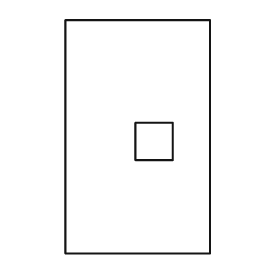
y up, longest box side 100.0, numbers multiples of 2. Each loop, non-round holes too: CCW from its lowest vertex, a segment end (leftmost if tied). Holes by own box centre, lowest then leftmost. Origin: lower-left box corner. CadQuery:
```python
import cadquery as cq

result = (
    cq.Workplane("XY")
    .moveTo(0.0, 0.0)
    .lineTo(62.0, 0.0)
    .lineTo(62.0, 100.0)
    .lineTo(0.0, 100.0)
    .close()
    .moveTo(30.0, 40.0)
    .lineTo(46.0, 40.0)
    .lineTo(46.0, 56.0)
    .lineTo(30.0, 56.0)
    .close()
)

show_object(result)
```